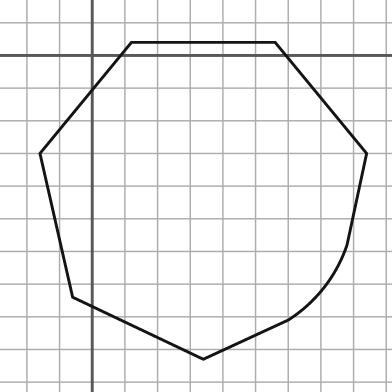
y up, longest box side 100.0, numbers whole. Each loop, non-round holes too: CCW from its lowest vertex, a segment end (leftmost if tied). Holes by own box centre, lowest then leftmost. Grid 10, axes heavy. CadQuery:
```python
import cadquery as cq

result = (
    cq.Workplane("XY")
    .moveTo(34.0, -93.0)
    .lineTo(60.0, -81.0)
    .threePointArc((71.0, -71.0), (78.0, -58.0))
    .lineTo(84.0, -30.0)
    .lineTo(56.0, 4.0)
    .lineTo(12.0, 4.0)
    .lineTo(-16.0, -30.0)
    .lineTo(-6.0, -74.0)
    .close()
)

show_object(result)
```